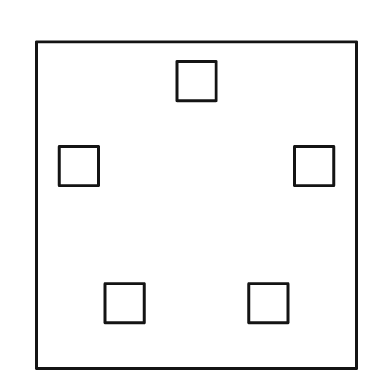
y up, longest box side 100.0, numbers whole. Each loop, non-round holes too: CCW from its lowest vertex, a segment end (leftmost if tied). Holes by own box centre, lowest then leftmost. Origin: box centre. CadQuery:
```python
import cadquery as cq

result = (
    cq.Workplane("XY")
    .moveTo(-49.0, -50.0)
    .lineTo(49.0, -50.0)
    .lineTo(49.0, 50.0)
    .lineTo(-49.0, 50.0)
    .close()
    .moveTo(-28.0, -36.0)
    .lineTo(-16.0, -36.0)
    .lineTo(-16.0, -24.0)
    .lineTo(-28.0, -24.0)
    .close()
    .moveTo(16.0, -36.0)
    .lineTo(28.0, -36.0)
    .lineTo(28.0, -24.0)
    .lineTo(16.0, -24.0)
    .close()
    .moveTo(-42.0, 6.0)
    .lineTo(-30.0, 6.0)
    .lineTo(-30.0, 18.0)
    .lineTo(-42.0, 18.0)
    .close()
    .moveTo(30.0, 6.0)
    .lineTo(42.0, 6.0)
    .lineTo(42.0, 18.0)
    .lineTo(30.0, 18.0)
    .close()
    .moveTo(-6.0, 32.0)
    .lineTo(6.0, 32.0)
    .lineTo(6.0, 44.0)
    .lineTo(-6.0, 44.0)
    .close()
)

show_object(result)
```